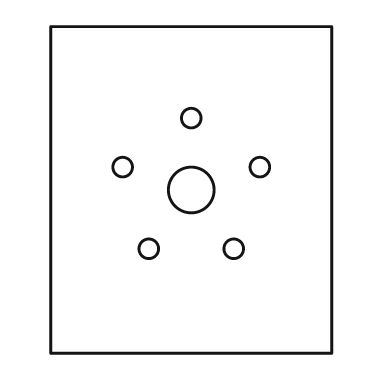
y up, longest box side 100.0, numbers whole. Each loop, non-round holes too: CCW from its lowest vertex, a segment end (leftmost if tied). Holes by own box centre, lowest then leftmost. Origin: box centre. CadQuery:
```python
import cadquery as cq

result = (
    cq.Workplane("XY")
    .moveTo(-43.0, -50.0)
    .lineTo(43.0, -50.0)
    .lineTo(43.0, 50.0)
    .lineTo(-43.0, 50.0)
    .close()
    .moveTo(-13.0, -18.0)
    .circle(3.0)
    .moveTo(13.0, -18.0)
    .circle(3.0)
    .moveTo(0.0, 0.0)
    .circle(7.0)
    .moveTo(-21.0, 7.0)
    .circle(3.0)
    .moveTo(21.0, 7.0)
    .circle(3.0)
    .moveTo(0.0, 22.0)
    .circle(3.0)
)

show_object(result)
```